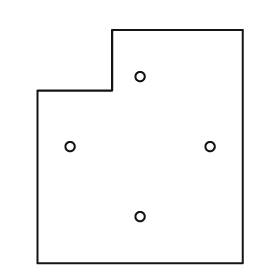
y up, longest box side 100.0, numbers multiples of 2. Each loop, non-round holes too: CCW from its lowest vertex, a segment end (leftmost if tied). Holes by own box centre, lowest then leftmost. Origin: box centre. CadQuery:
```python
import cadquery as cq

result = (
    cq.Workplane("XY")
    .moveTo(-44.0, -50.0)
    .lineTo(44.0, -50.0)
    .lineTo(44.0, 50.0)
    .lineTo(-12.0, 50.0)
    .lineTo(-12.0, 24.0)
    .lineTo(-44.0, 24.0)
    .close()
    .moveTo(0.0, -30.0)
    .circle(2.0)
    .moveTo(-30.0, 0.0)
    .circle(2.0)
    .moveTo(30.0, 0.0)
    .circle(2.0)
    .moveTo(0.0, 30.0)
    .circle(2.0)
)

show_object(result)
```